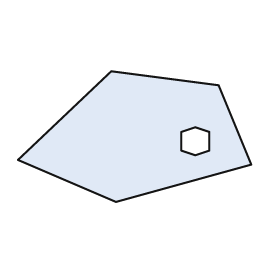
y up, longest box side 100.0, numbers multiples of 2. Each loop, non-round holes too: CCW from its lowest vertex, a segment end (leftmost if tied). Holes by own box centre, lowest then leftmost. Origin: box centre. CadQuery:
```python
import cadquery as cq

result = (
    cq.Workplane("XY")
    .moveTo(-8.0, -28.0)
    .lineTo(50.0, -12.0)
    .lineTo(36.0, 22.0)
    .lineTo(-10.0, 28.0)
    .lineTo(-50.0, -10.0)
    .close()
    .moveTo(26.0, -8.0)
    .lineTo(32.0, -6.0)
    .lineTo(32.0, 2.0)
    .lineTo(26.0, 4.0)
    .lineTo(20.0, 2.0)
    .lineTo(20.0, -6.0)
    .close()
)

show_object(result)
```